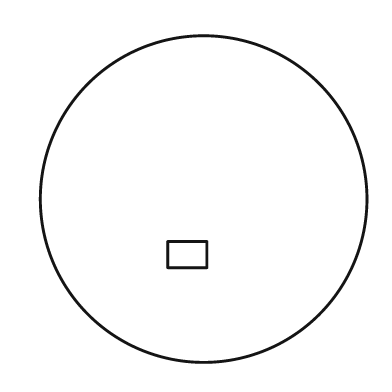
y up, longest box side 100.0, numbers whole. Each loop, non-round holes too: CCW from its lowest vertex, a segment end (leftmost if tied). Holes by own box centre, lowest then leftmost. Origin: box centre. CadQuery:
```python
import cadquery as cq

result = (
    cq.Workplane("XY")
    .moveTo(0.0, 0.0)
    .circle(50.0)
    .moveTo(-11.0, -21.0)
    .lineTo(1.0, -21.0)
    .lineTo(1.0, -13.0)
    .lineTo(-11.0, -13.0)
    .close()
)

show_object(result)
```